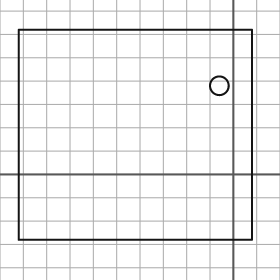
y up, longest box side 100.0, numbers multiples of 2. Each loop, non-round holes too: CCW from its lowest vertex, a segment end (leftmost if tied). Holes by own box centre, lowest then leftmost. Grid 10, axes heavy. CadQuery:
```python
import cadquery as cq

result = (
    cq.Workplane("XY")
    .moveTo(-92.0, -28.0)
    .lineTo(8.0, -28.0)
    .lineTo(8.0, 62.0)
    .lineTo(-92.0, 62.0)
    .close()
    .moveTo(-6.0, 38.0)
    .circle(4.0)
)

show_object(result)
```